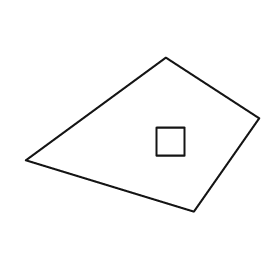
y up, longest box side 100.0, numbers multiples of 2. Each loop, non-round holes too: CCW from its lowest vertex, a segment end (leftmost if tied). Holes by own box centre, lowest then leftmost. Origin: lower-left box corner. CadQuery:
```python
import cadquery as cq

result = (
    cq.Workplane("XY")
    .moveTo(72.0, 0.0)
    .lineTo(100.0, 40.0)
    .lineTo(60.0, 66.0)
    .lineTo(0.0, 22.0)
    .close()
    .moveTo(56.0, 24.0)
    .lineTo(68.0, 24.0)
    .lineTo(68.0, 36.0)
    .lineTo(56.0, 36.0)
    .close()
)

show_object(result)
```